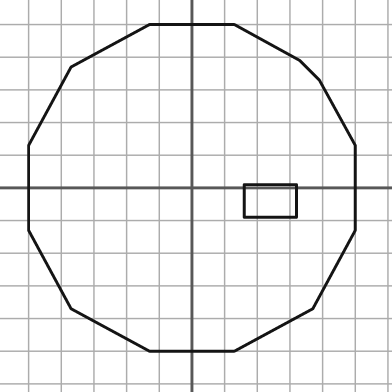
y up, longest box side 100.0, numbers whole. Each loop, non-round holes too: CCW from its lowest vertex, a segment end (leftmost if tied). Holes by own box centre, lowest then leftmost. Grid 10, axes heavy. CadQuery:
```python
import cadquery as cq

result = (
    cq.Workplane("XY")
    .moveTo(-13.0, -50.0)
    .lineTo(13.0, -50.0)
    .lineTo(37.0, -37.0)
    .lineTo(50.0, -13.0)
    .lineTo(50.0, 13.0)
    .lineTo(39.0, 33.0)
    .lineTo(33.0, 39.0)
    .lineTo(13.0, 50.0)
    .lineTo(-13.0, 50.0)
    .lineTo(-37.0, 37.0)
    .lineTo(-50.0, 13.0)
    .lineTo(-50.0, -13.0)
    .lineTo(-37.0, -37.0)
    .close()
    .moveTo(16.0, -9.0)
    .lineTo(32.0, -9.0)
    .lineTo(32.0, 1.0)
    .lineTo(16.0, 1.0)
    .close()
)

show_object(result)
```